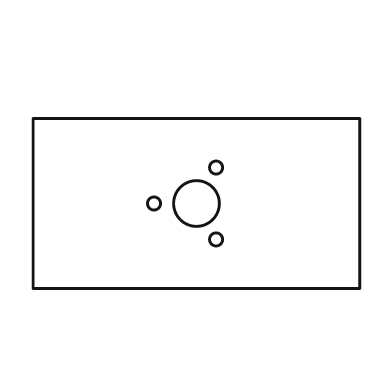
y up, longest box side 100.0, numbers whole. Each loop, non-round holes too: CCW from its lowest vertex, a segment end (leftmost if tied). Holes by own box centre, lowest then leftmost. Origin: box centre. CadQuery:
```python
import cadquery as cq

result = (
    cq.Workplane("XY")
    .moveTo(-50.0, -26.0)
    .lineTo(50.0, -26.0)
    .lineTo(50.0, 26.0)
    .lineTo(-50.0, 26.0)
    .close()
    .moveTo(6.0, -11.0)
    .circle(2.0)
    .moveTo(-13.0, 0.0)
    .circle(2.0)
    .moveTo(0.0, 0.0)
    .circle(7.0)
    .moveTo(6.0, 11.0)
    .circle(2.0)
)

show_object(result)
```